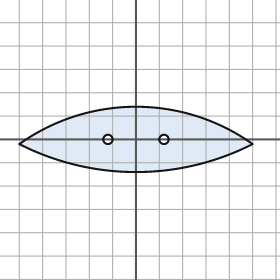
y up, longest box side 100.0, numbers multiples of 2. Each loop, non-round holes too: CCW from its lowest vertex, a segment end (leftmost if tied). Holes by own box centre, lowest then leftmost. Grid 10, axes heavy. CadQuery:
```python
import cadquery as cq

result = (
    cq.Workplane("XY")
    .moveTo(-50.0, -2.0)
    .threePointArc((0.0, -14.0), (50.0, -2.0))
    .threePointArc((0.0, 14.0), (-50.0, -2.0))
    .close()
    .moveTo(-12.0, 0.0)
    .circle(2.0)
    .moveTo(12.0, 0.0)
    .circle(2.0)
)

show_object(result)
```